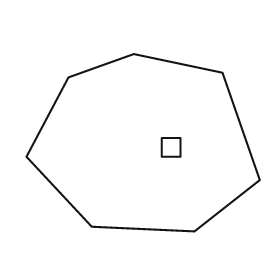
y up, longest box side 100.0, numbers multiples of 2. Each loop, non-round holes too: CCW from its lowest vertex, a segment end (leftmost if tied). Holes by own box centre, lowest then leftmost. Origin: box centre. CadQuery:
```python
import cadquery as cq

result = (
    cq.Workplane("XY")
    .moveTo(22.0, -38.0)
    .lineTo(50.0, -16.0)
    .lineTo(34.0, 30.0)
    .lineTo(-4.0, 38.0)
    .lineTo(-32.0, 28.0)
    .lineTo(-50.0, -6.0)
    .lineTo(-22.0, -36.0)
    .close()
    .moveTo(8.0, -6.0)
    .lineTo(16.0, -6.0)
    .lineTo(16.0, 2.0)
    .lineTo(8.0, 2.0)
    .close()
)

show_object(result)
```